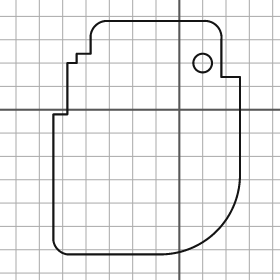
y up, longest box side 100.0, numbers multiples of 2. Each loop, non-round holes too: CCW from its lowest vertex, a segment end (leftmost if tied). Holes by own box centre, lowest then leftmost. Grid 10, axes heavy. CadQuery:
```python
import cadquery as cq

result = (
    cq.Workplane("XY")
    .moveTo(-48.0, -62.0)
    .lineTo(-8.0, -62.0)
    .threePointArc((16.0, -52.0), (26.0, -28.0))
    .lineTo(26.0, 14.0)
    .lineTo(18.0, 14.0)
    .lineTo(18.0, 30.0)
    .threePointArc((16.0, 36.0), (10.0, 38.0))
    .lineTo(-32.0, 38.0)
    .threePointArc((-36.0, 36.0), (-38.0, 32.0))
    .lineTo(-38.0, 24.0)
    .lineTo(-44.0, 24.0)
    .lineTo(-44.0, 20.0)
    .lineTo(-48.0, 20.0)
    .lineTo(-48.0, -2.0)
    .lineTo(-54.0, -2.0)
    .lineTo(-54.0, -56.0)
    .threePointArc((-52.0, -60.0), (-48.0, -62.0))
    .close()
    .moveTo(10.0, 20.0)
    .circle(4.0)
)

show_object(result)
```